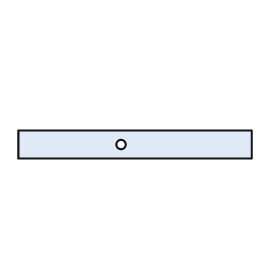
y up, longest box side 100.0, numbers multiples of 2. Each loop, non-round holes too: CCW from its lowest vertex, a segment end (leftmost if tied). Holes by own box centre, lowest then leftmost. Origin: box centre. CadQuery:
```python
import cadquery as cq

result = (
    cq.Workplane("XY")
    .moveTo(-50.0, -6.0)
    .lineTo(50.0, -6.0)
    .lineTo(50.0, 6.0)
    .lineTo(-50.0, 6.0)
    .close()
    .moveTo(-6.0, 0.0)
    .circle(2.0)
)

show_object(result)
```